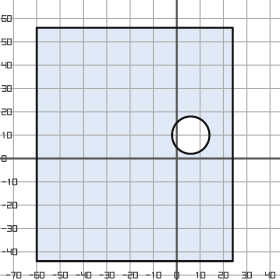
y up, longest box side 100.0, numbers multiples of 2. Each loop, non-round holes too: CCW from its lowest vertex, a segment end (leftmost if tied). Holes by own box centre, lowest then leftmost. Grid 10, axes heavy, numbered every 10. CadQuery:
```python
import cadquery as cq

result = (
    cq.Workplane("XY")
    .moveTo(-60.0, -44.0)
    .lineTo(24.0, -44.0)
    .lineTo(24.0, 56.0)
    .lineTo(-60.0, 56.0)
    .close()
    .moveTo(6.0, 10.0)
    .circle(8.0)
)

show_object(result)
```